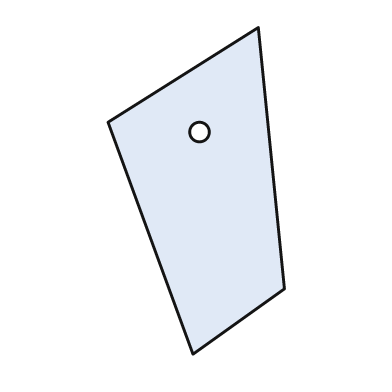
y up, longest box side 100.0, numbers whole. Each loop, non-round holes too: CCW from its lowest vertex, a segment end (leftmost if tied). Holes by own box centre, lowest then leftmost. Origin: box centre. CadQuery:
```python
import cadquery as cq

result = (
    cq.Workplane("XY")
    .moveTo(-1.0, -50.0)
    .lineTo(27.0, -30.0)
    .lineTo(19.0, 50.0)
    .lineTo(-27.0, 21.0)
    .close()
    .moveTo(1.0, 18.0)
    .circle(3.0)
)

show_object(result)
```